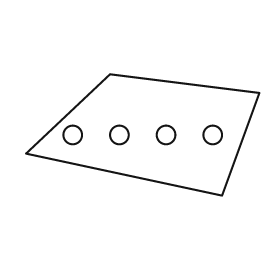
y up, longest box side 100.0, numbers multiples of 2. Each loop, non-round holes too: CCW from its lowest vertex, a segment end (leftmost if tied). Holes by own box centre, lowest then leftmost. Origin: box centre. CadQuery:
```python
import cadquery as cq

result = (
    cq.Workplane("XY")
    .moveTo(34.0, -26.0)
    .lineTo(50.0, 18.0)
    .lineTo(-14.0, 26.0)
    .lineTo(-50.0, -8.0)
    .close()
    .moveTo(-30.0, 0.0)
    .circle(4.0)
    .moveTo(-10.0, 0.0)
    .circle(4.0)
    .moveTo(10.0, 0.0)
    .circle(4.0)
    .moveTo(30.0, 0.0)
    .circle(4.0)
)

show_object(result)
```